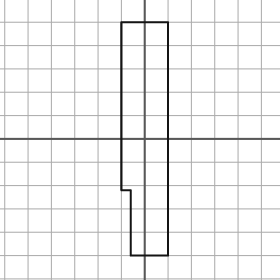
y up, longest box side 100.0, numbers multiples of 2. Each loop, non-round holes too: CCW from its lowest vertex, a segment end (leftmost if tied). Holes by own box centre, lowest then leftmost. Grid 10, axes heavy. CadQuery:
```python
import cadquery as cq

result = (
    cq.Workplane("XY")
    .moveTo(-6.0, -50.0)
    .lineTo(10.0, -50.0)
    .lineTo(10.0, 50.0)
    .lineTo(-10.0, 50.0)
    .lineTo(-10.0, -22.0)
    .lineTo(-6.0, -22.0)
    .close()
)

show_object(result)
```